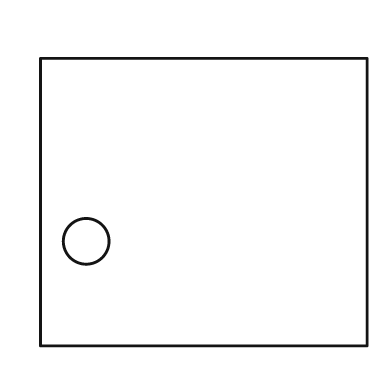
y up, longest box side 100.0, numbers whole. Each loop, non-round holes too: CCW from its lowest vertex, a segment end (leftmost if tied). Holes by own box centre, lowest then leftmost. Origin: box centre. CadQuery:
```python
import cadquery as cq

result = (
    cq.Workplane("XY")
    .moveTo(-50.0, -44.0)
    .lineTo(50.0, -44.0)
    .lineTo(50.0, 44.0)
    .lineTo(-50.0, 44.0)
    .close()
    .moveTo(-36.0, -12.0)
    .circle(7.0)
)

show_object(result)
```